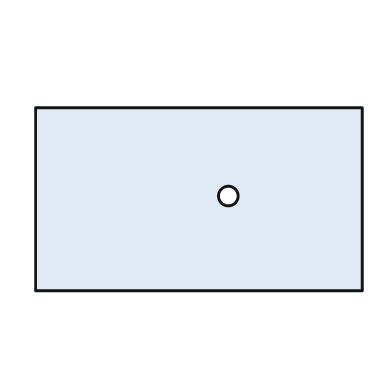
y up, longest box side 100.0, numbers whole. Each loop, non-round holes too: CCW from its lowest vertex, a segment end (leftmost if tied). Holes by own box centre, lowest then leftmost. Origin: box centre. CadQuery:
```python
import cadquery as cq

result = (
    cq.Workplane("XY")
    .moveTo(-50.0, -28.0)
    .lineTo(50.0, -28.0)
    .lineTo(50.0, 28.0)
    .lineTo(-50.0, 28.0)
    .close()
    .moveTo(9.0, 1.0)
    .circle(3.0)
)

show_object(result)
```